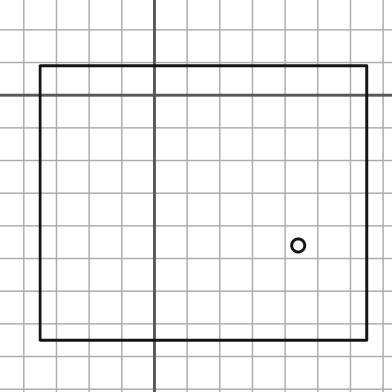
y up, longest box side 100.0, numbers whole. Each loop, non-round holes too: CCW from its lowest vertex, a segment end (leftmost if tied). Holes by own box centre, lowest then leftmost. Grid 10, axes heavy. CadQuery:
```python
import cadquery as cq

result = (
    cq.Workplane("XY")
    .moveTo(-35.0, -75.0)
    .lineTo(65.0, -75.0)
    .lineTo(65.0, 9.0)
    .lineTo(-35.0, 9.0)
    .close()
    .moveTo(44.0, -46.0)
    .circle(2.0)
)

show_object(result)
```